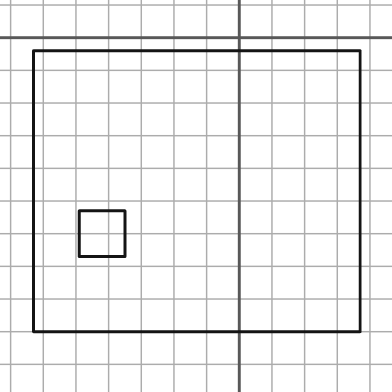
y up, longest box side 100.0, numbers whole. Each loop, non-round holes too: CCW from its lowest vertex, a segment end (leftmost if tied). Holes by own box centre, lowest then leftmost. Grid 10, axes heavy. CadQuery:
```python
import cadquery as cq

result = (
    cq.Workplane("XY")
    .moveTo(-63.0, -90.0)
    .lineTo(37.0, -90.0)
    .lineTo(37.0, -4.0)
    .lineTo(-63.0, -4.0)
    .close()
    .moveTo(-49.0, -67.0)
    .lineTo(-35.0, -67.0)
    .lineTo(-35.0, -53.0)
    .lineTo(-49.0, -53.0)
    .close()
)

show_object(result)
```